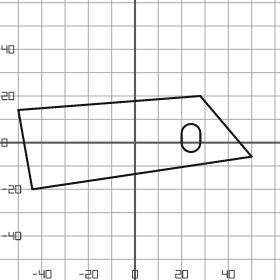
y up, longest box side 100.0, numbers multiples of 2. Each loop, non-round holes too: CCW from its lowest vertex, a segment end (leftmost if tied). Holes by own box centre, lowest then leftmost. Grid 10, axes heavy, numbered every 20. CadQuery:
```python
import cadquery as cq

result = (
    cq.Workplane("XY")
    .moveTo(-44.0, -20.0)
    .lineTo(50.0, -6.0)
    .lineTo(28.0, 20.0)
    .lineTo(-50.0, 14.0)
    .close()
    .moveTo(20.0, 0.0)
    .threePointArc((24.0, -4.0), (28.0, 0.0))
    .lineTo(28.0, 4.0)
    .threePointArc((24.0, 8.0), (20.0, 4.0))
    .close()
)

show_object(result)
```